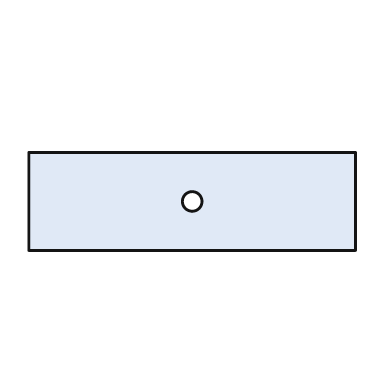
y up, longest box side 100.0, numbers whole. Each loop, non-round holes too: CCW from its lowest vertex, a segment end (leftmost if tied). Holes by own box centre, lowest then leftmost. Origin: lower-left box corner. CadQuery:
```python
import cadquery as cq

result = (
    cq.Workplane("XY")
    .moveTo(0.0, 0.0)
    .lineTo(100.0, 0.0)
    .lineTo(100.0, 30.0)
    .lineTo(0.0, 30.0)
    .close()
    .moveTo(50.0, 15.0)
    .circle(3.0)
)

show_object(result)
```